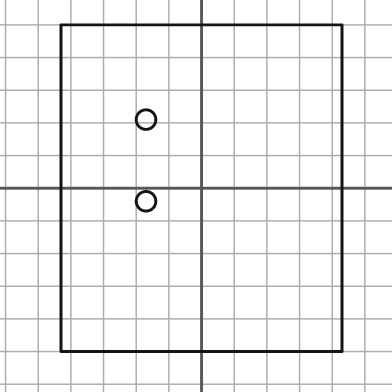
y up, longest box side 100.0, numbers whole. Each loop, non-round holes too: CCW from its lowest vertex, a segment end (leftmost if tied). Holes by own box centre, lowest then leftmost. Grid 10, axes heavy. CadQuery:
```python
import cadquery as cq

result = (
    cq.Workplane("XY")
    .moveTo(-43.0, -50.0)
    .lineTo(43.0, -50.0)
    .lineTo(43.0, 50.0)
    .lineTo(-43.0, 50.0)
    .close()
    .moveTo(-17.0, -4.0)
    .circle(3.0)
    .moveTo(-17.0, 21.0)
    .circle(3.0)
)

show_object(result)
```